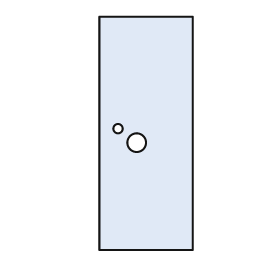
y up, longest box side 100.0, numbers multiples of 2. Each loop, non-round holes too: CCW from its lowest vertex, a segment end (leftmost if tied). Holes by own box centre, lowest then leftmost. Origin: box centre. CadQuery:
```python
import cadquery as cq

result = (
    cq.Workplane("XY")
    .moveTo(-20.0, -50.0)
    .lineTo(20.0, -50.0)
    .lineTo(20.0, 50.0)
    .lineTo(-20.0, 50.0)
    .close()
    .moveTo(-4.0, -4.0)
    .circle(4.0)
    .moveTo(-12.0, 2.0)
    .circle(2.0)
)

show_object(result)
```